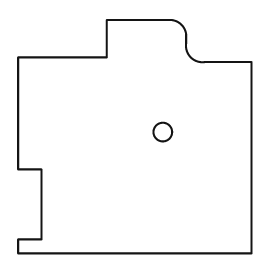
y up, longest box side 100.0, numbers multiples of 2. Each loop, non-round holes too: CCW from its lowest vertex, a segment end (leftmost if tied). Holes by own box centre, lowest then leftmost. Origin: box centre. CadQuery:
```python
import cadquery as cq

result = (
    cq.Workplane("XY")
    .moveTo(-50.0, -50.0)
    .lineTo(50.0, -50.0)
    .lineTo(50.0, 32.0)
    .lineTo(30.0, 32.0)
    .threePointArc((24.0, 34.0), (22.0, 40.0))
    .lineTo(22.0, 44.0)
    .threePointArc((20.0, 48.0), (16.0, 50.0))
    .lineTo(-12.0, 50.0)
    .lineTo(-12.0, 34.0)
    .lineTo(-50.0, 34.0)
    .lineTo(-50.0, -14.0)
    .lineTo(-40.0, -14.0)
    .lineTo(-40.0, -44.0)
    .lineTo(-50.0, -44.0)
    .close()
    .moveTo(12.0, 2.0)
    .circle(4.0)
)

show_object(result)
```